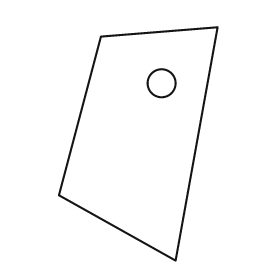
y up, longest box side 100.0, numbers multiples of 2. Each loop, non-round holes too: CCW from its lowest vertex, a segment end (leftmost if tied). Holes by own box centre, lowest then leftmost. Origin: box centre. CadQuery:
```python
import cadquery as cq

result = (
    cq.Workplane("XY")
    .moveTo(16.0, -50.0)
    .lineTo(34.0, 50.0)
    .lineTo(-16.0, 46.0)
    .lineTo(-34.0, -22.0)
    .close()
    .moveTo(10.0, 26.0)
    .circle(6.0)
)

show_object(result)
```